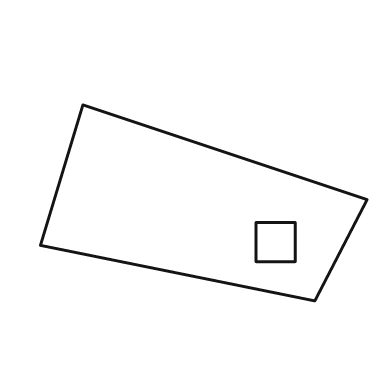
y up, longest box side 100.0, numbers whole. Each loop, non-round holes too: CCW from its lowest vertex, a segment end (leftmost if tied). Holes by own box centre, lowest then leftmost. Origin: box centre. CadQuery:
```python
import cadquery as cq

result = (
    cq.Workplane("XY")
    .moveTo(34.0, -30.0)
    .lineTo(50.0, 1.0)
    .lineTo(-37.0, 30.0)
    .lineTo(-50.0, -13.0)
    .close()
    .moveTo(16.0, -18.0)
    .lineTo(28.0, -18.0)
    .lineTo(28.0, -6.0)
    .lineTo(16.0, -6.0)
    .close()
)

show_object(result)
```